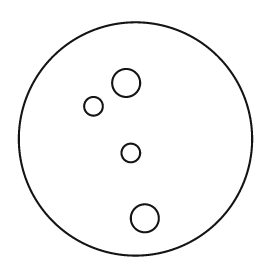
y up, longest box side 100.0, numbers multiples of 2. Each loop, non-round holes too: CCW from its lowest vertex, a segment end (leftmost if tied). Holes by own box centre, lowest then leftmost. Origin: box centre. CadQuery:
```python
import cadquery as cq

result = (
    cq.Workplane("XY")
    .moveTo(0.0, 0.0)
    .circle(50.0)
    .moveTo(4.0, -34.0)
    .circle(6.0)
    .moveTo(-2.0, -6.0)
    .circle(4.0)
    .moveTo(-18.0, 14.0)
    .circle(4.0)
    .moveTo(-4.0, 24.0)
    .circle(6.0)
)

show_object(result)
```